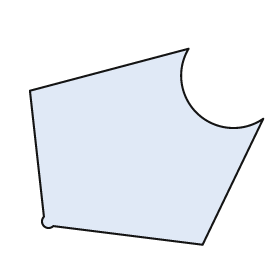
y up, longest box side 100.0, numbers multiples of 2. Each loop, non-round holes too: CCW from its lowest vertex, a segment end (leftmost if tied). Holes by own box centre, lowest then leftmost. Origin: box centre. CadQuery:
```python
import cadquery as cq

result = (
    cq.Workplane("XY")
    .moveTo(24.0, -42.0)
    .lineTo(50.0, 12.0)
    .threePointArc((22.0, 14.0), (18.0, 42.0))
    .lineTo(-50.0, 24.0)
    .lineTo(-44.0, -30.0)
    .threePointArc((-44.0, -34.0), (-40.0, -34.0))
    .close()
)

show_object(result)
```